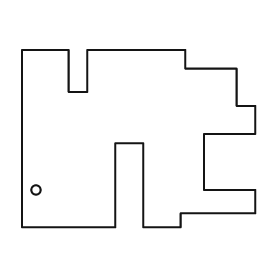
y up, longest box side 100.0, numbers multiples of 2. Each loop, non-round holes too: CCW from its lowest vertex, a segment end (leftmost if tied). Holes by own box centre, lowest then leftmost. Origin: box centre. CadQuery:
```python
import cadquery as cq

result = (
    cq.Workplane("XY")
    .moveTo(-50.0, -38.0)
    .lineTo(-10.0, -38.0)
    .lineTo(-10.0, -2.0)
    .lineTo(2.0, -2.0)
    .lineTo(2.0, -38.0)
    .lineTo(18.0, -38.0)
    .lineTo(18.0, -32.0)
    .lineTo(50.0, -32.0)
    .lineTo(50.0, -22.0)
    .lineTo(28.0, -22.0)
    .lineTo(28.0, 2.0)
    .lineTo(50.0, 2.0)
    .lineTo(50.0, 14.0)
    .lineTo(42.0, 14.0)
    .lineTo(42.0, 30.0)
    .lineTo(20.0, 30.0)
    .lineTo(20.0, 38.0)
    .lineTo(-22.0, 38.0)
    .lineTo(-22.0, 20.0)
    .lineTo(-30.0, 20.0)
    .lineTo(-30.0, 38.0)
    .lineTo(-50.0, 38.0)
    .close()
    .moveTo(-44.0, -22.0)
    .circle(2.0)
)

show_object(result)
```